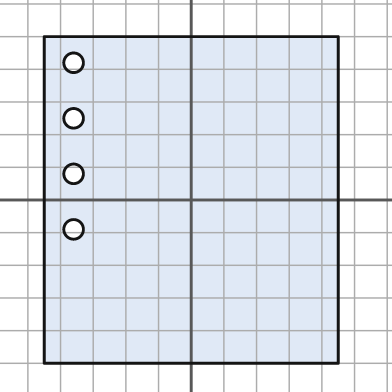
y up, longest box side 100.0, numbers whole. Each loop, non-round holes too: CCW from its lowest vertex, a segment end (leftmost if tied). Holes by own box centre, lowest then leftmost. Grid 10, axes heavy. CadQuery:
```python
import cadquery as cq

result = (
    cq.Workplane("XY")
    .moveTo(-45.0, -50.0)
    .lineTo(45.0, -50.0)
    .lineTo(45.0, 50.0)
    .lineTo(-45.0, 50.0)
    .close()
    .moveTo(-36.0, -9.0)
    .circle(3.0)
    .moveTo(-36.0, 8.0)
    .circle(3.0)
    .moveTo(-36.0, 25.0)
    .circle(3.0)
    .moveTo(-36.0, 42.0)
    .circle(3.0)
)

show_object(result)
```